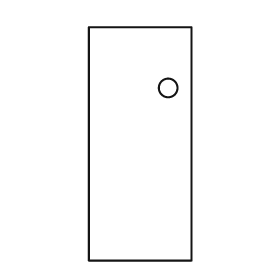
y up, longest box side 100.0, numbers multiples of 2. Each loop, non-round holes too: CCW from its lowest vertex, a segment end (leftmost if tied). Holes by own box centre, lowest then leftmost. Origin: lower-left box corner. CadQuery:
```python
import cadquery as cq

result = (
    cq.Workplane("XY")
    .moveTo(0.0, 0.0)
    .lineTo(44.0, 0.0)
    .lineTo(44.0, 100.0)
    .lineTo(0.0, 100.0)
    .close()
    .moveTo(34.0, 74.0)
    .circle(4.0)
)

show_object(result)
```